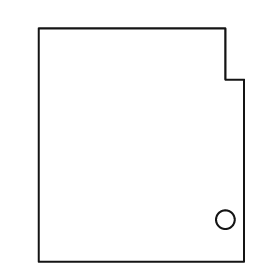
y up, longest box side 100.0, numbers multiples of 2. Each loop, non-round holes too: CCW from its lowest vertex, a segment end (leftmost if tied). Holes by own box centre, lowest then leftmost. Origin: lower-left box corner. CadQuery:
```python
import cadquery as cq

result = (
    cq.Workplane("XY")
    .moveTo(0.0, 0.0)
    .lineTo(88.0, 0.0)
    .lineTo(88.0, 78.0)
    .lineTo(80.0, 78.0)
    .lineTo(80.0, 100.0)
    .lineTo(0.0, 100.0)
    .close()
    .moveTo(80.0, 18.0)
    .circle(4.0)
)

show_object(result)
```